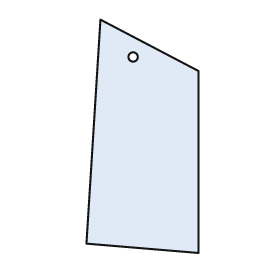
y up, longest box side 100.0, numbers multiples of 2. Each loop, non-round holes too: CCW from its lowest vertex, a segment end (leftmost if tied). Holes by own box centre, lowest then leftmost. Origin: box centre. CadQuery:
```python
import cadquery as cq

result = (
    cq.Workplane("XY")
    .moveTo(24.0, -50.0)
    .lineTo(24.0, 28.0)
    .lineTo(-18.0, 50.0)
    .lineTo(-24.0, -46.0)
    .close()
    .moveTo(-4.0, 34.0)
    .circle(2.0)
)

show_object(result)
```